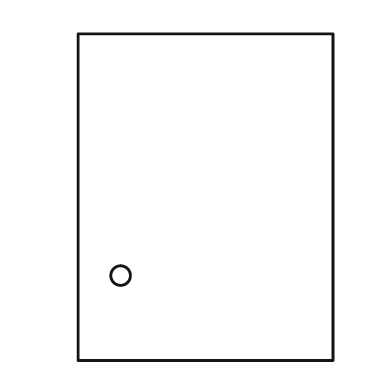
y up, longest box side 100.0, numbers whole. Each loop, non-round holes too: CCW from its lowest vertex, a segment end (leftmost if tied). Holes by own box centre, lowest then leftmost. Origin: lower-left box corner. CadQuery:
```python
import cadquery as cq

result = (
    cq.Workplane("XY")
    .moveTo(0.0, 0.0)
    .lineTo(78.0, 0.0)
    .lineTo(78.0, 100.0)
    .lineTo(0.0, 100.0)
    .close()
    .moveTo(13.0, 26.0)
    .circle(3.0)
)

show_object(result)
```